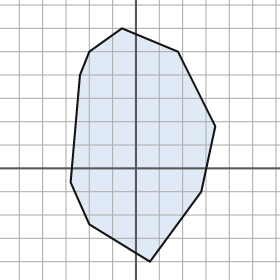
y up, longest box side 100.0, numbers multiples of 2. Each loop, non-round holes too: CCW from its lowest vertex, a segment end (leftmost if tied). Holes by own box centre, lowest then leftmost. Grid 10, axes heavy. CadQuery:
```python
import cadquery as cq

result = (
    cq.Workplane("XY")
    .moveTo(6.0, -40.0)
    .lineTo(28.0, -10.0)
    .lineTo(34.0, 18.0)
    .lineTo(18.0, 50.0)
    .lineTo(-6.0, 60.0)
    .lineTo(-20.0, 50.0)
    .lineTo(-24.0, 40.0)
    .lineTo(-28.0, -6.0)
    .lineTo(-20.0, -24.0)
    .close()
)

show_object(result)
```